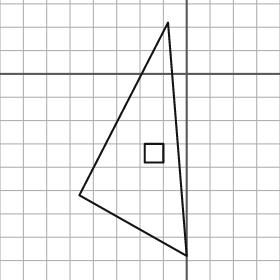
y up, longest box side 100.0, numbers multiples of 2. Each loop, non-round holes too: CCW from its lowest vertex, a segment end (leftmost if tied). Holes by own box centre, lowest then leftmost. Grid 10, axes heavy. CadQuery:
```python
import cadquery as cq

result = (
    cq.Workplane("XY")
    .moveTo(0.0, -78.0)
    .lineTo(-8.0, 22.0)
    .lineTo(-46.0, -52.0)
    .close()
    .moveTo(-18.0, -38.0)
    .lineTo(-10.0, -38.0)
    .lineTo(-10.0, -30.0)
    .lineTo(-18.0, -30.0)
    .close()
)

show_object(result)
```